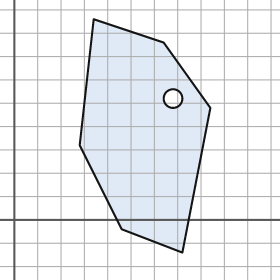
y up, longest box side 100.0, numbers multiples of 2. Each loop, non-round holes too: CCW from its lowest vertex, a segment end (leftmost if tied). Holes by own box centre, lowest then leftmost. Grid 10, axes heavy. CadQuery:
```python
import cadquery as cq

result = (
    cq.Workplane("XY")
    .moveTo(72.0, -14.0)
    .lineTo(84.0, 48.0)
    .lineTo(64.0, 76.0)
    .lineTo(34.0, 86.0)
    .lineTo(28.0, 32.0)
    .lineTo(46.0, -4.0)
    .close()
    .moveTo(68.0, 52.0)
    .circle(4.0)
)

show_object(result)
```